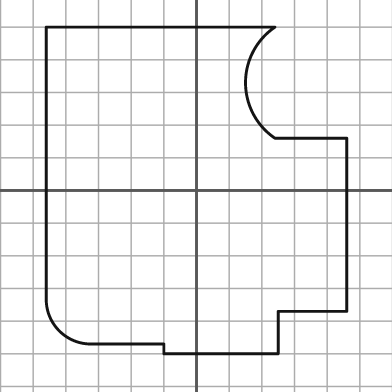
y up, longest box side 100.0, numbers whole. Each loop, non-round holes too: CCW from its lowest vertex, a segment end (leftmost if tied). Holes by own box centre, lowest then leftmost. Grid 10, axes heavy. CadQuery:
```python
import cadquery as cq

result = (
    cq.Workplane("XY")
    .moveTo(-10.0, -50.0)
    .lineTo(25.0, -50.0)
    .lineTo(25.0, -37.0)
    .lineTo(46.0, -37.0)
    .lineTo(46.0, 16.0)
    .lineTo(24.0, 16.0)
    .threePointArc((15.0, 33.0), (24.0, 50.0))
    .lineTo(-46.0, 50.0)
    .lineTo(-46.0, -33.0)
    .threePointArc((-42.0, -43.0), (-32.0, -47.0))
    .lineTo(-10.0, -47.0)
    .close()
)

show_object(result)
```